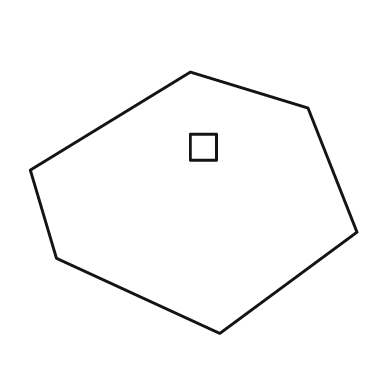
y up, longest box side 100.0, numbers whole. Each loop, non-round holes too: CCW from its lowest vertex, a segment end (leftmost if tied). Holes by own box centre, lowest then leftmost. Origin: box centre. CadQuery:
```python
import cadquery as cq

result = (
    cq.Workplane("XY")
    .moveTo(8.0, -40.0)
    .lineTo(50.0, -9.0)
    .lineTo(35.0, 29.0)
    .lineTo(-1.0, 40.0)
    .lineTo(-50.0, 10.0)
    .lineTo(-42.0, -17.0)
    .close()
    .moveTo(-1.0, 13.0)
    .lineTo(7.0, 13.0)
    .lineTo(7.0, 21.0)
    .lineTo(-1.0, 21.0)
    .close()
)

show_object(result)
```